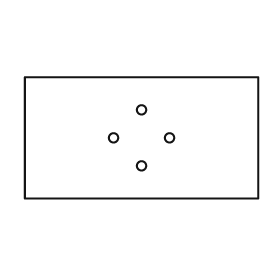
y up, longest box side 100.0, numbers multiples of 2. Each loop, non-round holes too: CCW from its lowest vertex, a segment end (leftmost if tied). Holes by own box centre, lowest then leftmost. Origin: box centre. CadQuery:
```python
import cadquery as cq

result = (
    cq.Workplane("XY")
    .moveTo(-50.0, -26.0)
    .lineTo(50.0, -26.0)
    .lineTo(50.0, 26.0)
    .lineTo(-50.0, 26.0)
    .close()
    .moveTo(0.0, -12.0)
    .circle(2.0)
    .moveTo(-12.0, 0.0)
    .circle(2.0)
    .moveTo(12.0, 0.0)
    .circle(2.0)
    .moveTo(0.0, 12.0)
    .circle(2.0)
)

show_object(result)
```